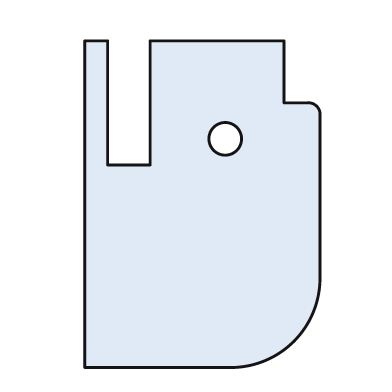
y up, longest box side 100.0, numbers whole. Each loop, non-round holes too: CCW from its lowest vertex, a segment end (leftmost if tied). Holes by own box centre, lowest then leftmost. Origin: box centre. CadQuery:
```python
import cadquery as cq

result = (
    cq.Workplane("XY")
    .moveTo(-36.0, -50.0)
    .lineTo(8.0, -50.0)
    .threePointArc((28.0, -42.0), (36.0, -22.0))
    .lineTo(36.0, 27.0)
    .threePointArc((35.0, 30.0), (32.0, 31.0))
    .lineTo(25.0, 31.0)
    .lineTo(25.0, 50.0)
    .lineTo(-16.0, 50.0)
    .lineTo(-16.0, 12.0)
    .lineTo(-29.0, 12.0)
    .lineTo(-29.0, 50.0)
    .lineTo(-36.0, 50.0)
    .close()
    .moveTo(7.0, 20.0)
    .circle(5.0)
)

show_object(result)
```